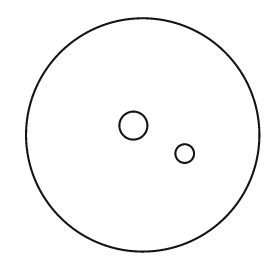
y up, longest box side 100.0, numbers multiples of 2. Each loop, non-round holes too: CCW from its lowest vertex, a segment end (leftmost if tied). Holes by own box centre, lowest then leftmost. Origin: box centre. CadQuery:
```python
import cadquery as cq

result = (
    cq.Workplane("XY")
    .moveTo(0.0, 0.0)
    .circle(50.0)
    .moveTo(18.0, -8.0)
    .circle(4.0)
    .moveTo(-4.0, 4.0)
    .circle(6.0)
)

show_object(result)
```